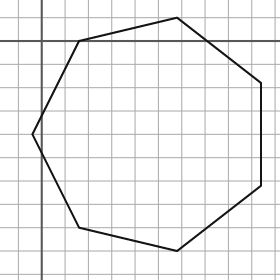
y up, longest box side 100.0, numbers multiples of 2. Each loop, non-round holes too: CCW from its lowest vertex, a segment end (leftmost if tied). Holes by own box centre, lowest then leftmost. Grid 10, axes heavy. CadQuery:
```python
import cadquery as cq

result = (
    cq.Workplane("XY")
    .moveTo(58.0, -90.0)
    .lineTo(94.0, -62.0)
    .lineTo(94.0, -18.0)
    .lineTo(58.0, 10.0)
    .lineTo(16.0, 0.0)
    .lineTo(-4.0, -40.0)
    .lineTo(16.0, -80.0)
    .close()
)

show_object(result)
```